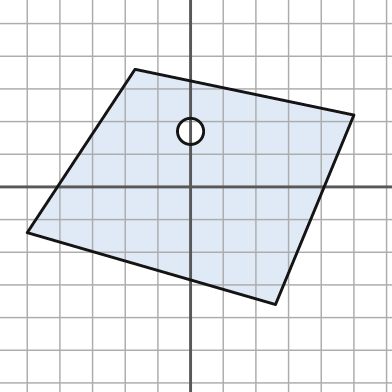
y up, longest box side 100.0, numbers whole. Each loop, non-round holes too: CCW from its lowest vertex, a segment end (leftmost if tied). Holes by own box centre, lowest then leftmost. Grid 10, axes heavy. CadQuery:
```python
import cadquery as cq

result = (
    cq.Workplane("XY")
    .moveTo(26.0, -36.0)
    .lineTo(50.0, 22.0)
    .lineTo(-17.0, 36.0)
    .lineTo(-50.0, -14.0)
    .close()
    .moveTo(0.0, 17.0)
    .circle(4.0)
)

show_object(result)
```